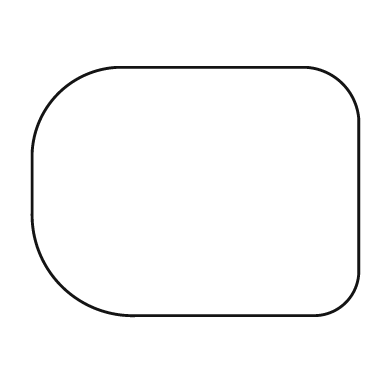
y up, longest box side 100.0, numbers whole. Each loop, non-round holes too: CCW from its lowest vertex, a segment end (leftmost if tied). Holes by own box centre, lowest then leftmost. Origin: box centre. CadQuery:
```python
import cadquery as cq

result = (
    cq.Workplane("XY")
    .moveTo(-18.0, -38.0)
    .lineTo(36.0, -38.0)
    .threePointArc((46.0, -34.0), (50.0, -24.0))
    .lineTo(50.0, 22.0)
    .threePointArc((45.0, 33.0), (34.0, 38.0))
    .lineTo(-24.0, 38.0)
    .threePointArc((-42.0, 30.0), (-50.0, 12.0))
    .lineTo(-50.0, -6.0)
    .threePointArc((-41.0, -29.0), (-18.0, -38.0))
    .close()
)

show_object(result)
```